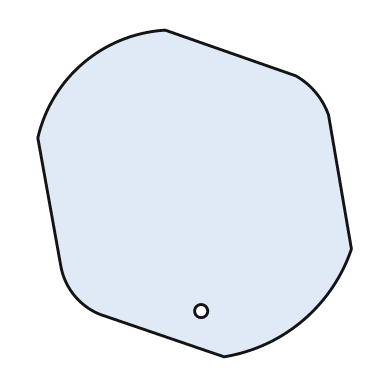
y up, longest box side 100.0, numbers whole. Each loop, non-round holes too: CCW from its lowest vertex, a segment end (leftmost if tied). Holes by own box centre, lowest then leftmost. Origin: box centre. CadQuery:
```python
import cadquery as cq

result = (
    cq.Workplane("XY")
    .moveTo(9.0, -50.0)
    .threePointArc((33.0, -39.0), (48.0, -17.0))
    .lineTo(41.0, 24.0)
    .threePointArc((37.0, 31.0), (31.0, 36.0))
    .lineTo(-9.0, 50.0)
    .threePointArc((-34.0, 40.0), (-48.0, 17.0))
    .lineTo(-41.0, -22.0)
    .threePointArc((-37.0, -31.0), (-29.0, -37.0))
    .close()
    .moveTo(2.0, -36.0)
    .circle(2.0)
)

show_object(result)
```